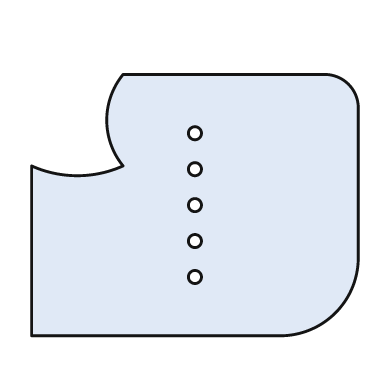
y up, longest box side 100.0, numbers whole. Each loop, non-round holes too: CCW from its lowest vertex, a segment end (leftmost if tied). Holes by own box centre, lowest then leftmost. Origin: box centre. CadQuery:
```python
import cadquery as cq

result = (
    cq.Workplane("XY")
    .moveTo(-50.0, -40.0)
    .lineTo(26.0, -40.0)
    .threePointArc((43.0, -33.0), (50.0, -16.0))
    .lineTo(50.0, 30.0)
    .threePointArc((47.0, 37.0), (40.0, 40.0))
    .lineTo(-22.0, 40.0)
    .threePointArc((-27.0, 26.0), (-22.0, 12.0))
    .threePointArc((-36.0, 9.0), (-50.0, 12.0))
    .close()
    .moveTo(0.0, -22.0)
    .circle(2.0)
    .moveTo(0.0, -11.0)
    .circle(2.0)
    .moveTo(0.0, 0.0)
    .circle(2.0)
    .moveTo(0.0, 11.0)
    .circle(2.0)
    .moveTo(0.0, 22.0)
    .circle(2.0)
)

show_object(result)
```